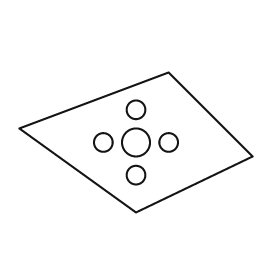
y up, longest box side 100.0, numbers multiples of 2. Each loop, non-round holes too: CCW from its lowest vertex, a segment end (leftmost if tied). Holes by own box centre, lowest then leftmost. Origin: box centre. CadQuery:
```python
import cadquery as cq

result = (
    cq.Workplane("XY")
    .moveTo(0.0, -30.0)
    .lineTo(50.0, -6.0)
    .lineTo(14.0, 30.0)
    .lineTo(-50.0, 6.0)
    .close()
    .moveTo(0.0, -14.0)
    .circle(4.0)
    .moveTo(-14.0, 0.0)
    .circle(4.0)
    .moveTo(0.0, 0.0)
    .circle(6.0)
    .moveTo(14.0, 0.0)
    .circle(4.0)
    .moveTo(0.0, 14.0)
    .circle(4.0)
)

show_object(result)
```